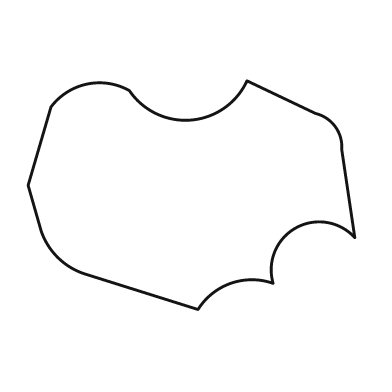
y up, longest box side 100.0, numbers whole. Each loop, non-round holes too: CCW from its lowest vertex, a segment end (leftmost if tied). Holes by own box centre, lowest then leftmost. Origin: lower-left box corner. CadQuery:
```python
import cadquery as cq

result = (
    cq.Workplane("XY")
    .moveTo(52.0, 0.0)
    .threePointArc((62.0, 8.0), (75.0, 8.0))
    .threePointArc((82.0, 25.0), (100.0, 22.0))
    .lineTo(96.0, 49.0)
    .threePointArc((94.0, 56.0), (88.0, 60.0))
    .lineTo(67.0, 70.0)
    .threePointArc((50.0, 58.0), (31.0, 67.0))
    .threePointArc((18.0, 69.0), (7.0, 62.0))
    .lineTo(0.0, 38.0)
    .lineTo(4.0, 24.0)
    .threePointArc((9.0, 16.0), (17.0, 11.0))
    .close()
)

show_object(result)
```